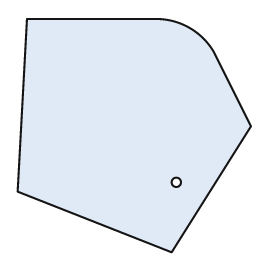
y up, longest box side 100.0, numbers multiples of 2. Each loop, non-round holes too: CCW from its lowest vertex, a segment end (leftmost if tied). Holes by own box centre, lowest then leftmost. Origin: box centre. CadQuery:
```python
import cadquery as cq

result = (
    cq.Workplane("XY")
    .moveTo(16.0, -50.0)
    .lineTo(50.0, 4.0)
    .lineTo(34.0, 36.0)
    .threePointArc((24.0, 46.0), (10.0, 50.0))
    .lineTo(-46.0, 50.0)
    .lineTo(-50.0, -24.0)
    .close()
    .moveTo(18.0, -20.0)
    .circle(2.0)
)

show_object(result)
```